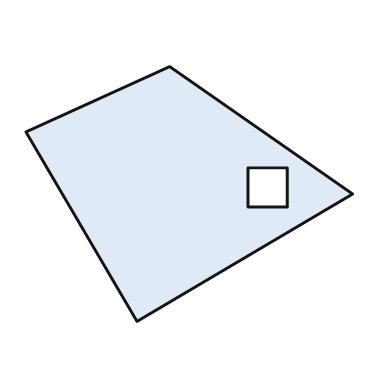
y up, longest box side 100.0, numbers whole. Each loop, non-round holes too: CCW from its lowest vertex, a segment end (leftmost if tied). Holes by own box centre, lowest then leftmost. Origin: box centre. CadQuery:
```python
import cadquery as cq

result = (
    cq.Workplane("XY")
    .moveTo(-16.0, -39.0)
    .lineTo(50.0, 0.0)
    .lineTo(-6.0, 39.0)
    .lineTo(-50.0, 19.0)
    .close()
    .moveTo(18.0, -4.0)
    .lineTo(30.0, -4.0)
    .lineTo(30.0, 8.0)
    .lineTo(18.0, 8.0)
    .close()
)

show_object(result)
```